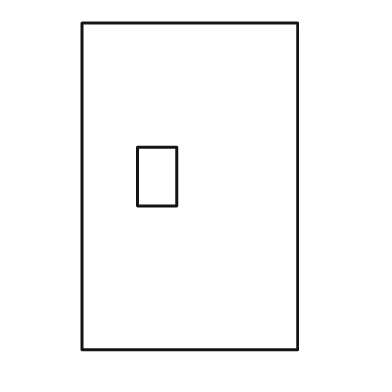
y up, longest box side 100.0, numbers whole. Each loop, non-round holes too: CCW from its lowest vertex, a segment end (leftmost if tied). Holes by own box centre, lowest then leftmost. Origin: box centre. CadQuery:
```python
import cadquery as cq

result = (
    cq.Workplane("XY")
    .moveTo(-33.0, -50.0)
    .lineTo(33.0, -50.0)
    .lineTo(33.0, 50.0)
    .lineTo(-33.0, 50.0)
    .close()
    .moveTo(-16.0, -6.0)
    .lineTo(-4.0, -6.0)
    .lineTo(-4.0, 12.0)
    .lineTo(-16.0, 12.0)
    .close()
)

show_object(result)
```